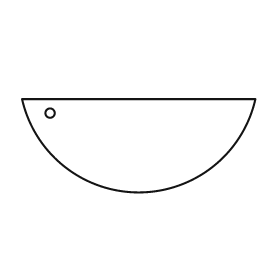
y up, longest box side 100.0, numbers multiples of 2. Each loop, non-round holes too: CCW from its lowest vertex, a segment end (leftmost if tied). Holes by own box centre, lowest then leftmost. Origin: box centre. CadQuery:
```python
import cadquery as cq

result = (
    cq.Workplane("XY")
    .moveTo(-50.0, 20.0)
    .threePointArc((0.0, -20.0), (50.0, 20.0))
    .close()
    .moveTo(-38.0, 14.0)
    .circle(2.0)
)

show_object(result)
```